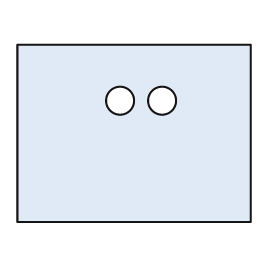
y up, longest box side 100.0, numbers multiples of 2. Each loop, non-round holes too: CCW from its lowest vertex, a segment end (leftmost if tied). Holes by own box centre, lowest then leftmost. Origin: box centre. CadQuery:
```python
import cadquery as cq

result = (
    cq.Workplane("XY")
    .moveTo(-50.0, -38.0)
    .lineTo(50.0, -38.0)
    .lineTo(50.0, 38.0)
    .lineTo(-50.0, 38.0)
    .close()
    .moveTo(-6.0, 14.0)
    .circle(6.0)
    .moveTo(12.0, 14.0)
    .circle(6.0)
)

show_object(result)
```